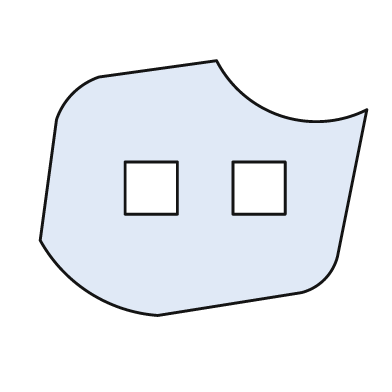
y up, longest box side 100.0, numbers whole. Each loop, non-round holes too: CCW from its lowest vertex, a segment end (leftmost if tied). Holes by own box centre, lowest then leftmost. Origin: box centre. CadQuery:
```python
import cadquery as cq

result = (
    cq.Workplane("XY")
    .moveTo(-14.0, -39.0)
    .lineTo(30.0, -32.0)
    .threePointArc((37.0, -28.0), (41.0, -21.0))
    .lineTo(50.0, 24.0)
    .threePointArc((24.0, 22.0), (4.0, 39.0))
    .lineTo(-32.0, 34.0)
    .threePointArc((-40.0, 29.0), (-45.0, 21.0))
    .lineTo(-50.0, -16.0)
    .threePointArc((-35.0, -32.0), (-14.0, -39.0))
    .close()
    .moveTo(-24.0, -8.0)
    .lineTo(-8.0, -8.0)
    .lineTo(-8.0, 8.0)
    .lineTo(-24.0, 8.0)
    .close()
    .moveTo(9.0, -8.0)
    .lineTo(25.0, -8.0)
    .lineTo(25.0, 8.0)
    .lineTo(9.0, 8.0)
    .close()
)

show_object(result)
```